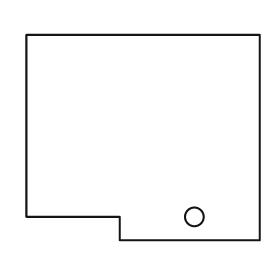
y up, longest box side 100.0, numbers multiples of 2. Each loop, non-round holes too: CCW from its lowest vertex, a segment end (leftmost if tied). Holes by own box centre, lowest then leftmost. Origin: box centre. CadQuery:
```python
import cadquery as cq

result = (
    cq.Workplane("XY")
    .moveTo(-10.0, -44.0)
    .lineTo(50.0, -44.0)
    .lineTo(50.0, 44.0)
    .lineTo(-50.0, 44.0)
    .lineTo(-50.0, -34.0)
    .lineTo(-10.0, -34.0)
    .close()
    .moveTo(22.0, -34.0)
    .circle(4.0)
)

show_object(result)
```